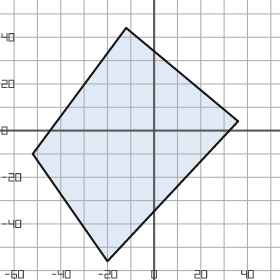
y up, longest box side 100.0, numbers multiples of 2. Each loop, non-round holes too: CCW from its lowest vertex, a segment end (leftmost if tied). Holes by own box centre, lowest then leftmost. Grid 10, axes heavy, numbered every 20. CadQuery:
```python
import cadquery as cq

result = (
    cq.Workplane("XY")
    .moveTo(-20.0, -56.0)
    .lineTo(36.0, 4.0)
    .lineTo(-12.0, 44.0)
    .lineTo(-52.0, -10.0)
    .close()
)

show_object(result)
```